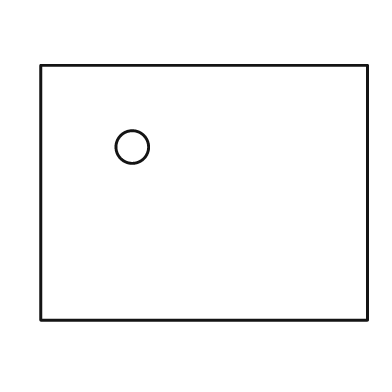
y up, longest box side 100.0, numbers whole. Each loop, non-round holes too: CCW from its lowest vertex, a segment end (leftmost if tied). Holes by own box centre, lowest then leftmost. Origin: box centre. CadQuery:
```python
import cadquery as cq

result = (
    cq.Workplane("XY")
    .moveTo(-50.0, -39.0)
    .lineTo(50.0, -39.0)
    .lineTo(50.0, 39.0)
    .lineTo(-50.0, 39.0)
    .close()
    .moveTo(-22.0, 14.0)
    .circle(5.0)
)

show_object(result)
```